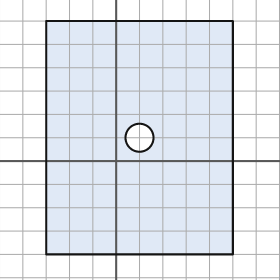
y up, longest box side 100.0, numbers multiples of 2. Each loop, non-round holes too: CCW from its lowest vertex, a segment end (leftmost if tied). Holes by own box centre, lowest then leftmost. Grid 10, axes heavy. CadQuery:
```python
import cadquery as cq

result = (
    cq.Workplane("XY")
    .moveTo(-30.0, -40.0)
    .lineTo(50.0, -40.0)
    .lineTo(50.0, 60.0)
    .lineTo(-30.0, 60.0)
    .close()
    .moveTo(10.0, 10.0)
    .circle(6.0)
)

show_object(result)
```